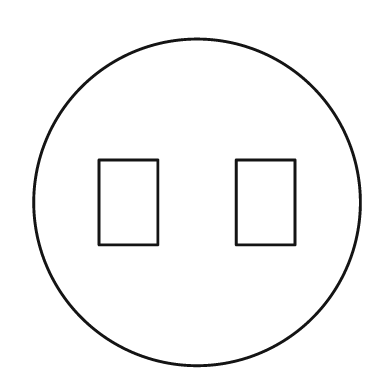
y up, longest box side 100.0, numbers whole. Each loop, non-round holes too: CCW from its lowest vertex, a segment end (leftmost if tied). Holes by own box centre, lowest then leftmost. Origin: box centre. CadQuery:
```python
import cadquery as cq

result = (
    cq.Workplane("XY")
    .moveTo(0.0, 0.0)
    .circle(50.0)
    .moveTo(-30.0, -13.0)
    .lineTo(-12.0, -13.0)
    .lineTo(-12.0, 13.0)
    .lineTo(-30.0, 13.0)
    .close()
    .moveTo(12.0, -13.0)
    .lineTo(30.0, -13.0)
    .lineTo(30.0, 13.0)
    .lineTo(12.0, 13.0)
    .close()
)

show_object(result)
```